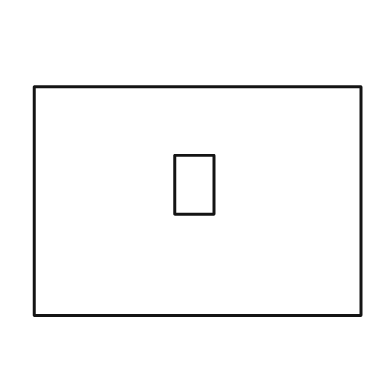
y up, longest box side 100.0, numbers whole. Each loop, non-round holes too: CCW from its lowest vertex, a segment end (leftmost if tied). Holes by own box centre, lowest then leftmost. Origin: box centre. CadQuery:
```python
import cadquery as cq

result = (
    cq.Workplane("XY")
    .moveTo(-50.0, -35.0)
    .lineTo(50.0, -35.0)
    .lineTo(50.0, 35.0)
    .lineTo(-50.0, 35.0)
    .close()
    .moveTo(-7.0, -4.0)
    .lineTo(5.0, -4.0)
    .lineTo(5.0, 14.0)
    .lineTo(-7.0, 14.0)
    .close()
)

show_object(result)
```